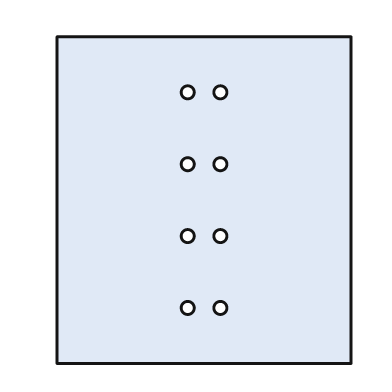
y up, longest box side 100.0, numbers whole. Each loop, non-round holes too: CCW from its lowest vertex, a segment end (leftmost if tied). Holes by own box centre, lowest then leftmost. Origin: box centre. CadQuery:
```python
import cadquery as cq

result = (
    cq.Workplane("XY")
    .moveTo(-45.0, -50.0)
    .lineTo(45.0, -50.0)
    .lineTo(45.0, 50.0)
    .lineTo(-45.0, 50.0)
    .close()
    .moveTo(-5.0, -33.0)
    .circle(2.0)
    .moveTo(5.0, -33.0)
    .circle(2.0)
    .moveTo(-5.0, -11.0)
    .circle(2.0)
    .moveTo(5.0, -11.0)
    .circle(2.0)
    .moveTo(-5.0, 11.0)
    .circle(2.0)
    .moveTo(5.0, 11.0)
    .circle(2.0)
    .moveTo(-5.0, 33.0)
    .circle(2.0)
    .moveTo(5.0, 33.0)
    .circle(2.0)
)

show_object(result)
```